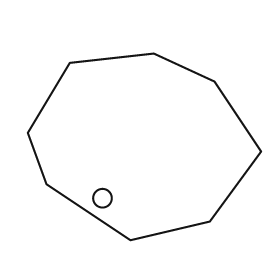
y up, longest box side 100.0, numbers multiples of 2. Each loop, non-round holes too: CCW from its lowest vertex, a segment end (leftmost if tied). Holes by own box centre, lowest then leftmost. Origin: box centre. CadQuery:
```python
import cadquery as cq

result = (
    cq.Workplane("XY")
    .moveTo(-6.0, -40.0)
    .lineTo(28.0, -32.0)
    .lineTo(50.0, -2.0)
    .lineTo(30.0, 28.0)
    .lineTo(4.0, 40.0)
    .lineTo(-32.0, 36.0)
    .lineTo(-50.0, 6.0)
    .lineTo(-42.0, -16.0)
    .close()
    .moveTo(-18.0, -22.0)
    .circle(4.0)
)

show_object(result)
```